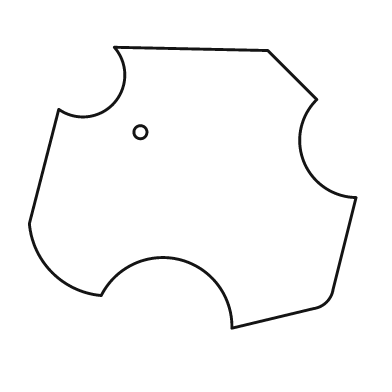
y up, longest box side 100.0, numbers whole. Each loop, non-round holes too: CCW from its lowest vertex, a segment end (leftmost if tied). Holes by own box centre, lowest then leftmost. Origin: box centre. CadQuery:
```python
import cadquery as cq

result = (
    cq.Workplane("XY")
    .moveTo(12.0, -43.0)
    .lineTo(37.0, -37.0)
    .threePointArc((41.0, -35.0), (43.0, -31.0))
    .lineTo(50.0, -3.0)
    .threePointArc((34.0, 8.0), (38.0, 27.0))
    .lineTo(23.0, 42.0)
    .lineTo(-24.0, 43.0)
    .threePointArc((-24.0, 26.0), (-41.0, 24.0))
    .lineTo(-50.0, -11.0)
    .threePointArc((-43.0, -26.0), (-28.0, -33.0))
    .threePointArc((-4.0, -22.0), (12.0, -43.0))
    .close()
    .moveTo(-16.0, 17.0)
    .circle(2.0)
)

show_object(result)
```